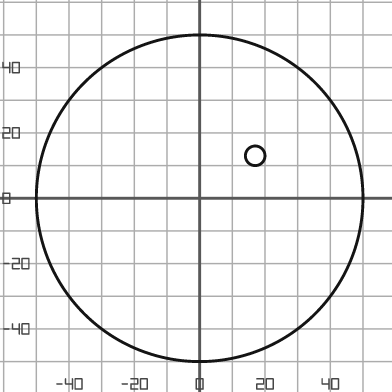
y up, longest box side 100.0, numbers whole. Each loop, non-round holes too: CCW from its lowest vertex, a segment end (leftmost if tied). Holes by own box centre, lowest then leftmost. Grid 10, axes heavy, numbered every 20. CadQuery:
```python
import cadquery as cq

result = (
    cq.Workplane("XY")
    .moveTo(0.0, 0.0)
    .circle(50.0)
    .moveTo(17.0, 13.0)
    .circle(3.0)
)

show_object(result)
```